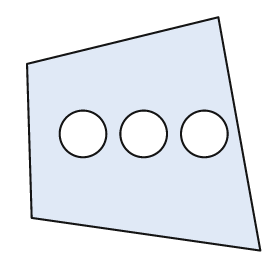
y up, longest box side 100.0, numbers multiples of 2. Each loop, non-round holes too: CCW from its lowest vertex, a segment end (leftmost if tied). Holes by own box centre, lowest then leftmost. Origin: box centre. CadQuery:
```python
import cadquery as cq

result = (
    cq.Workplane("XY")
    .moveTo(50.0, -50.0)
    .lineTo(32.0, 50.0)
    .lineTo(-50.0, 30.0)
    .lineTo(-48.0, -36.0)
    .close()
    .moveTo(-26.0, 0.0)
    .circle(10.0)
    .moveTo(0.0, 0.0)
    .circle(10.0)
    .moveTo(26.0, 0.0)
    .circle(10.0)
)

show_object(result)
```